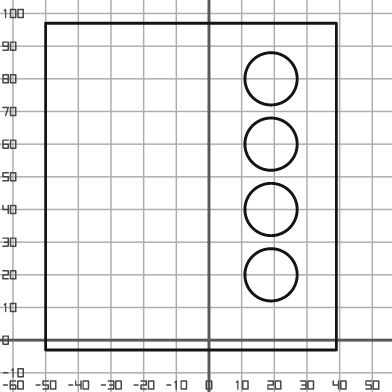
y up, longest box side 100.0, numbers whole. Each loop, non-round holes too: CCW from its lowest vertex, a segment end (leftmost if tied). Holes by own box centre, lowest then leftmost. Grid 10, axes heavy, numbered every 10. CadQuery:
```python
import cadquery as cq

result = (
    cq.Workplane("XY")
    .moveTo(-50.0, -3.0)
    .lineTo(39.0, -3.0)
    .lineTo(39.0, 97.0)
    .lineTo(-50.0, 97.0)
    .close()
    .moveTo(19.0, 20.0)
    .circle(8.0)
    .moveTo(19.0, 40.0)
    .circle(8.0)
    .moveTo(19.0, 60.0)
    .circle(8.0)
    .moveTo(19.0, 80.0)
    .circle(8.0)
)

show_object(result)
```